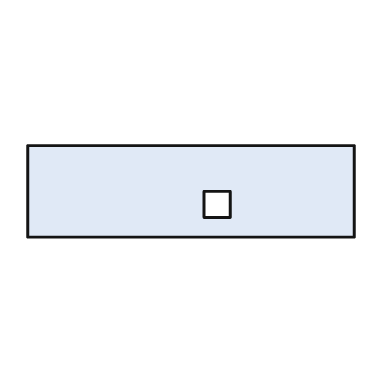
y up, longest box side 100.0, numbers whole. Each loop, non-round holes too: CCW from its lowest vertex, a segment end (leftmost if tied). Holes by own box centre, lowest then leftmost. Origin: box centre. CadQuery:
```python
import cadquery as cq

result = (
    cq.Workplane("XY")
    .moveTo(-50.0, -14.0)
    .lineTo(50.0, -14.0)
    .lineTo(50.0, 14.0)
    .lineTo(-50.0, 14.0)
    .close()
    .moveTo(4.0, -8.0)
    .lineTo(12.0, -8.0)
    .lineTo(12.0, 0.0)
    .lineTo(4.0, 0.0)
    .close()
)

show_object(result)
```